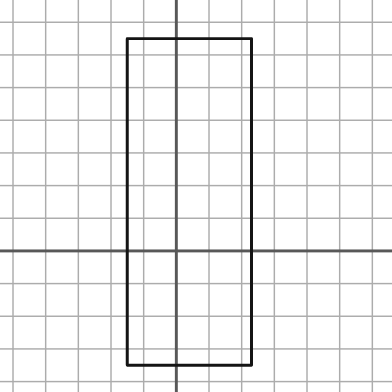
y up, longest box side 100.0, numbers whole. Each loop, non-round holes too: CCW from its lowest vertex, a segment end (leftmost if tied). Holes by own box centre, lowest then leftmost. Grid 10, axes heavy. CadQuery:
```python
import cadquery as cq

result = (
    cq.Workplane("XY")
    .moveTo(-15.0, -35.0)
    .lineTo(23.0, -35.0)
    .lineTo(23.0, 65.0)
    .lineTo(-15.0, 65.0)
    .close()
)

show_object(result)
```